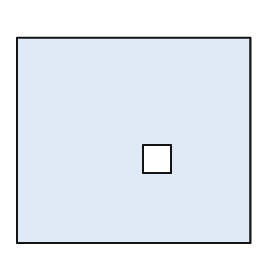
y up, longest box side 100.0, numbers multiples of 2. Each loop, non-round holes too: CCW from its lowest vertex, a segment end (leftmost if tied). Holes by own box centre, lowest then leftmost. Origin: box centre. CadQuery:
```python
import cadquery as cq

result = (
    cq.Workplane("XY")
    .moveTo(-50.0, -44.0)
    .lineTo(50.0, -44.0)
    .lineTo(50.0, 44.0)
    .lineTo(-50.0, 44.0)
    .close()
    .moveTo(4.0, -14.0)
    .lineTo(16.0, -14.0)
    .lineTo(16.0, -2.0)
    .lineTo(4.0, -2.0)
    .close()
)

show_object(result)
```